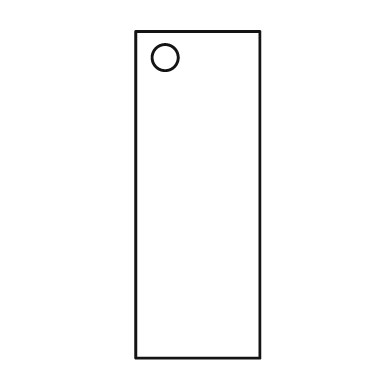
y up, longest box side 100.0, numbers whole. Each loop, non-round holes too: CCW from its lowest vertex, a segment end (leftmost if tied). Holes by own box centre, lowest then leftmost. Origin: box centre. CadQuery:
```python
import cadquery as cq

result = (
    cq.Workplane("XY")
    .moveTo(-19.0, -50.0)
    .lineTo(19.0, -50.0)
    .lineTo(19.0, 50.0)
    .lineTo(-19.0, 50.0)
    .close()
    .moveTo(-10.0, 42.0)
    .circle(4.0)
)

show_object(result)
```